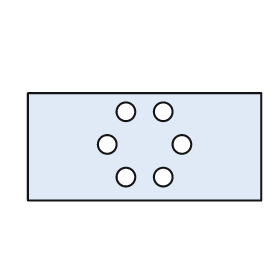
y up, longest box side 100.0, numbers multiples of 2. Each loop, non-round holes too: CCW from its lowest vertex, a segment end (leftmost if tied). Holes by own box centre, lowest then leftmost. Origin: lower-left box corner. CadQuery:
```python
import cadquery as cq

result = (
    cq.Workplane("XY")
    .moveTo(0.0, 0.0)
    .lineTo(100.0, 0.0)
    .lineTo(100.0, 46.0)
    .lineTo(0.0, 46.0)
    .close()
    .moveTo(42.0, 10.0)
    .circle(4.0)
    .moveTo(58.0, 10.0)
    .circle(4.0)
    .moveTo(34.0, 24.0)
    .circle(4.0)
    .moveTo(66.0, 24.0)
    .circle(4.0)
    .moveTo(42.0, 38.0)
    .circle(4.0)
    .moveTo(58.0, 38.0)
    .circle(4.0)
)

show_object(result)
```